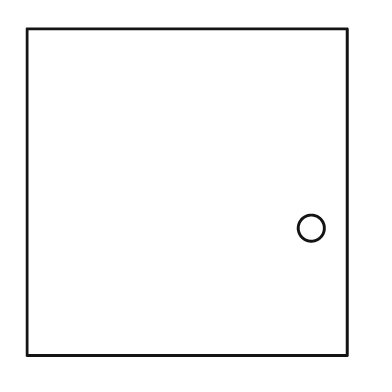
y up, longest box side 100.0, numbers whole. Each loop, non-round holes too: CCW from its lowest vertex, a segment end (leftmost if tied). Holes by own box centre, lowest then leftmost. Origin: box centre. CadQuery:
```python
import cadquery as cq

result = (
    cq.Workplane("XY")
    .moveTo(-49.0, -50.0)
    .lineTo(49.0, -50.0)
    .lineTo(49.0, 50.0)
    .lineTo(-49.0, 50.0)
    .close()
    .moveTo(38.0, -11.0)
    .circle(4.0)
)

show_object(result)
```